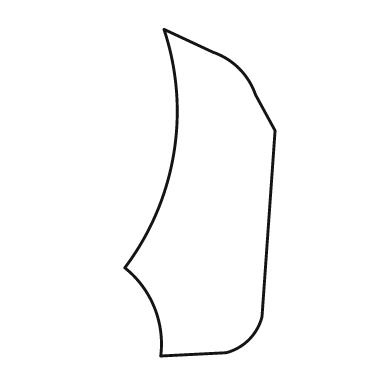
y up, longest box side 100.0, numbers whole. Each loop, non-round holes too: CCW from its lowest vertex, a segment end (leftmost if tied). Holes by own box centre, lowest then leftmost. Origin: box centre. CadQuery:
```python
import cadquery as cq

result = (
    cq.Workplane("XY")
    .moveTo(-12.0, -50.0)
    .lineTo(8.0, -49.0)
    .threePointArc((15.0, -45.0), (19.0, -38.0))
    .lineTo(23.0, 19.0)
    .lineTo(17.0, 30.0)
    .threePointArc((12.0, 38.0), (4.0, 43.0))
    .lineTo(-11.0, 50.0)
    .threePointArc((-8.0, 12.0), (-23.0, -23.0))
    .threePointArc((-14.0, -35.0), (-12.0, -50.0))
    .close()
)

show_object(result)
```